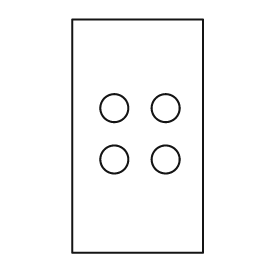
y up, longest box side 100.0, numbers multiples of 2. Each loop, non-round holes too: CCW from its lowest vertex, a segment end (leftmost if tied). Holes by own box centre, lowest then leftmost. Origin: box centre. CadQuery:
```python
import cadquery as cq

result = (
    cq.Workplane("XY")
    .moveTo(-28.0, -50.0)
    .lineTo(28.0, -50.0)
    .lineTo(28.0, 50.0)
    .lineTo(-28.0, 50.0)
    .close()
    .moveTo(-10.0, -10.0)
    .circle(6.0)
    .moveTo(12.0, -10.0)
    .circle(6.0)
    .moveTo(-10.0, 12.0)
    .circle(6.0)
    .moveTo(12.0, 12.0)
    .circle(6.0)
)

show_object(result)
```